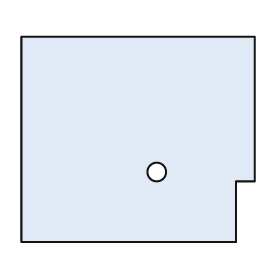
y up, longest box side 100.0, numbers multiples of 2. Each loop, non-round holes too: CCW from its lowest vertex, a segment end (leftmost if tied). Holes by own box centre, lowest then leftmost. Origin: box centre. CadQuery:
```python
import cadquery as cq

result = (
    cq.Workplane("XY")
    .moveTo(-50.0, -44.0)
    .lineTo(42.0, -44.0)
    .lineTo(42.0, -18.0)
    .lineTo(50.0, -18.0)
    .lineTo(50.0, 44.0)
    .lineTo(-50.0, 44.0)
    .close()
    .moveTo(8.0, -14.0)
    .circle(4.0)
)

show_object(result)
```